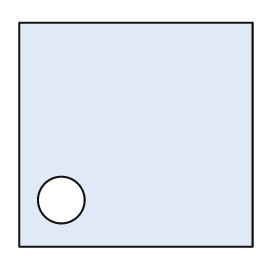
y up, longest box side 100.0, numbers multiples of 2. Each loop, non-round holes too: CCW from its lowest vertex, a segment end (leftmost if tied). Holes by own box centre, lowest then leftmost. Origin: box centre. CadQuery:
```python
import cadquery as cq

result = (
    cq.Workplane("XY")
    .moveTo(-50.0, -48.0)
    .lineTo(50.0, -48.0)
    .lineTo(50.0, 48.0)
    .lineTo(-50.0, 48.0)
    .close()
    .moveTo(-32.0, -28.0)
    .circle(10.0)
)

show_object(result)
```